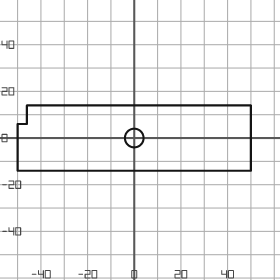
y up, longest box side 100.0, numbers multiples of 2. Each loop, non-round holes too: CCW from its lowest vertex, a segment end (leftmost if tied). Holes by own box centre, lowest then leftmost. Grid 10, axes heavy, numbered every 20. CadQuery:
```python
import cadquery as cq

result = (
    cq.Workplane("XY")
    .moveTo(-50.0, -14.0)
    .lineTo(50.0, -14.0)
    .lineTo(50.0, 14.0)
    .lineTo(-46.0, 14.0)
    .lineTo(-46.0, 6.0)
    .lineTo(-50.0, 6.0)
    .close()
    .moveTo(0.0, 0.0)
    .circle(4.0)
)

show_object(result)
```